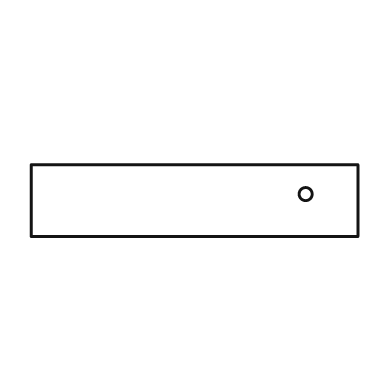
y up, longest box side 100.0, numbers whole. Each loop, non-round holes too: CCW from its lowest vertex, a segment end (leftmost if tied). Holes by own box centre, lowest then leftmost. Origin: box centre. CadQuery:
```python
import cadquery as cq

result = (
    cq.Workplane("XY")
    .moveTo(-50.0, -11.0)
    .lineTo(50.0, -11.0)
    .lineTo(50.0, 11.0)
    .lineTo(-50.0, 11.0)
    .close()
    .moveTo(34.0, 2.0)
    .circle(2.0)
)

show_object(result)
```